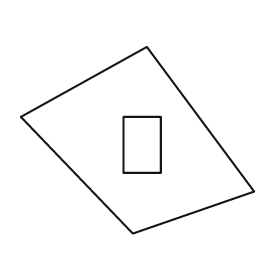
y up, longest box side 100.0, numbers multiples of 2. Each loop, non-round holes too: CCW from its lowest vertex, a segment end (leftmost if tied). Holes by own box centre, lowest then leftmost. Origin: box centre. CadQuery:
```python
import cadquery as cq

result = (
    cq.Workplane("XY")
    .moveTo(-2.0, -40.0)
    .lineTo(50.0, -22.0)
    .lineTo(4.0, 40.0)
    .lineTo(-50.0, 10.0)
    .close()
    .moveTo(-6.0, -14.0)
    .lineTo(10.0, -14.0)
    .lineTo(10.0, 10.0)
    .lineTo(-6.0, 10.0)
    .close()
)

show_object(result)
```